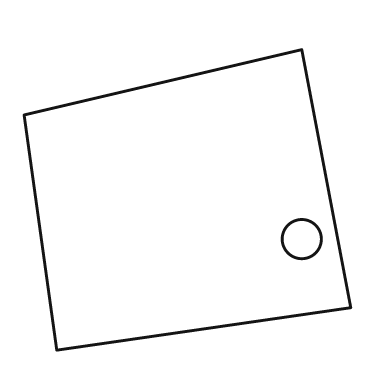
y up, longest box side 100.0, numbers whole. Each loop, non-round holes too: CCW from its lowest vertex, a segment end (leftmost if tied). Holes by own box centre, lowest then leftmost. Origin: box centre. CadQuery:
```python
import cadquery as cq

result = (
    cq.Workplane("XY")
    .moveTo(-40.0, -46.0)
    .lineTo(50.0, -33.0)
    .lineTo(35.0, 46.0)
    .lineTo(-50.0, 26.0)
    .close()
    .moveTo(35.0, -12.0)
    .circle(6.0)
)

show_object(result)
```